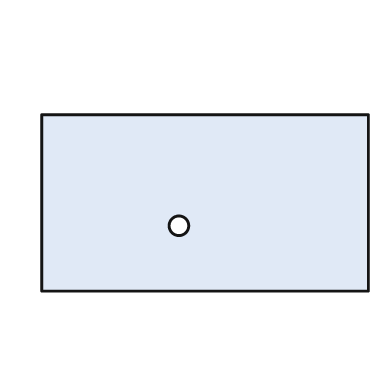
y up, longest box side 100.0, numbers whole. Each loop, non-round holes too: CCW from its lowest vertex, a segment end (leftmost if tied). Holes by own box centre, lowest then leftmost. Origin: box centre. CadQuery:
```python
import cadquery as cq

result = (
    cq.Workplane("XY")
    .moveTo(-50.0, -27.0)
    .lineTo(50.0, -27.0)
    .lineTo(50.0, 27.0)
    .lineTo(-50.0, 27.0)
    .close()
    .moveTo(-8.0, -7.0)
    .circle(3.0)
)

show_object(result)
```